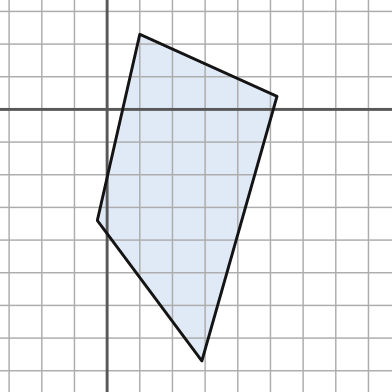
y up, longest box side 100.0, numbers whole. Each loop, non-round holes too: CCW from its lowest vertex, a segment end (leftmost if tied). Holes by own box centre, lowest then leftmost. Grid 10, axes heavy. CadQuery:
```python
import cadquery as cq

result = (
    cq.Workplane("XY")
    .moveTo(29.0, -77.0)
    .lineTo(52.0, 4.0)
    .lineTo(10.0, 23.0)
    .lineTo(-3.0, -34.0)
    .close()
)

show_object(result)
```